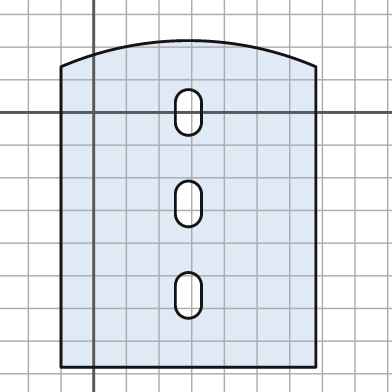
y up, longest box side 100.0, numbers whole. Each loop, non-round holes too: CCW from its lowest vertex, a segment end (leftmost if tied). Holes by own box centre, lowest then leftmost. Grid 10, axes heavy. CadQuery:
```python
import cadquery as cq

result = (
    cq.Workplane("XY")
    .moveTo(-10.0, -78.0)
    .lineTo(68.0, -78.0)
    .lineTo(68.0, 14.0)
    .threePointArc((29.0, 22.0), (-10.0, 14.0))
    .close()
    .moveTo(25.0, -59.0)
    .threePointArc((29.0, -63.0), (33.0, -59.0))
    .lineTo(33.0, -53.0)
    .threePointArc((29.0, -49.0), (25.0, -53.0))
    .close()
    .moveTo(25.0, -31.0)
    .threePointArc((29.0, -35.0), (33.0, -31.0))
    .lineTo(33.0, -25.0)
    .threePointArc((29.0, -21.0), (25.0, -25.0))
    .close()
    .moveTo(25.0, -3.0)
    .threePointArc((29.0, -7.0), (33.0, -3.0))
    .lineTo(33.0, 3.0)
    .threePointArc((29.0, 7.0), (25.0, 3.0))
    .close()
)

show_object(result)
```